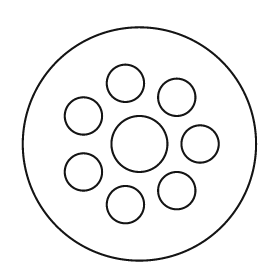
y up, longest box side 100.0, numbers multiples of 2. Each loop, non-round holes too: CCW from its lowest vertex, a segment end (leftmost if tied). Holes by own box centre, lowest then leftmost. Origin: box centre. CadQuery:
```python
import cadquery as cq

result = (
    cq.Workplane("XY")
    .moveTo(0.0, 0.0)
    .circle(50.0)
    .moveTo(-6.0, -26.0)
    .circle(8.0)
    .moveTo(16.0, -20.0)
    .circle(8.0)
    .moveTo(-24.0, -12.0)
    .circle(8.0)
    .moveTo(0.0, 0.0)
    .circle(12.0)
    .moveTo(26.0, 0.0)
    .circle(8.0)
    .moveTo(-24.0, 12.0)
    .circle(8.0)
    .moveTo(16.0, 20.0)
    .circle(8.0)
    .moveTo(-6.0, 26.0)
    .circle(8.0)
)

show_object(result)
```